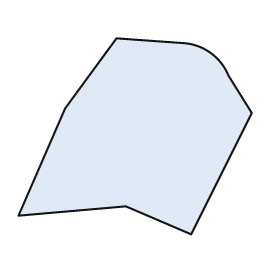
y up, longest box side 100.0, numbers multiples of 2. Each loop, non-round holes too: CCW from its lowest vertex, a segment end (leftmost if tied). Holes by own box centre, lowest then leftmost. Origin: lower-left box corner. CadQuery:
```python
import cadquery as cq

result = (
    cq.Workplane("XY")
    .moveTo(74.0, 0.0)
    .lineTo(100.0, 52.0)
    .lineTo(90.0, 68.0)
    .threePointArc((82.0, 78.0), (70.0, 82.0))
    .lineTo(42.0, 84.0)
    .lineTo(20.0, 54.0)
    .lineTo(0.0, 8.0)
    .lineTo(46.0, 12.0)
    .close()
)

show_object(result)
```